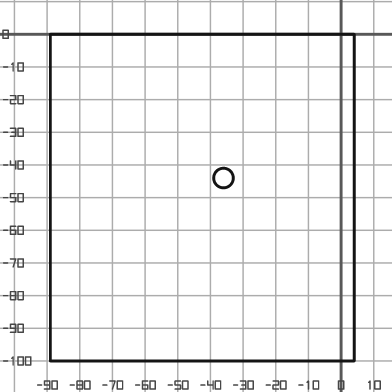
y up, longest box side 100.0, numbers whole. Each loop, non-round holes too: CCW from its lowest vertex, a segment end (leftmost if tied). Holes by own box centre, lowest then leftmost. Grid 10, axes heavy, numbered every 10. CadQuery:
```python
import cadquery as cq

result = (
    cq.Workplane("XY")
    .moveTo(-89.0, -100.0)
    .lineTo(4.0, -100.0)
    .lineTo(4.0, 0.0)
    .lineTo(-89.0, 0.0)
    .close()
    .moveTo(-36.0, -44.0)
    .circle(3.0)
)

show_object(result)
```